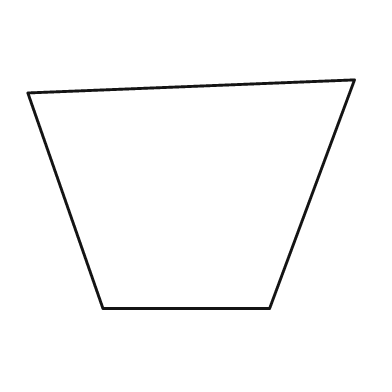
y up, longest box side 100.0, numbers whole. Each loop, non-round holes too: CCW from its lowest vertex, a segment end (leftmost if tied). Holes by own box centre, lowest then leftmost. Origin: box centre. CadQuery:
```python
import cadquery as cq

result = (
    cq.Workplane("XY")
    .moveTo(-27.0, -35.0)
    .lineTo(24.0, -35.0)
    .lineTo(50.0, 35.0)
    .lineTo(-50.0, 31.0)
    .close()
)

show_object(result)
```